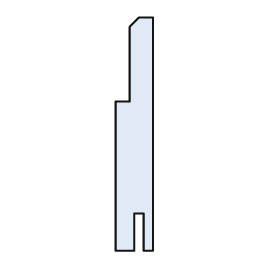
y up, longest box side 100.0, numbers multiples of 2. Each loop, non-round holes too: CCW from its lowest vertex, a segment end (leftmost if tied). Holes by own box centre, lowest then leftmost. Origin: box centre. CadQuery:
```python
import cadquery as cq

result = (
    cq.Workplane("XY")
    .moveTo(-8.0, -50.0)
    .lineTo(0.0, -50.0)
    .lineTo(0.0, -34.0)
    .lineTo(4.0, -34.0)
    .lineTo(4.0, -50.0)
    .lineTo(8.0, -50.0)
    .lineTo(8.0, 50.0)
    .lineTo(2.0, 50.0)
    .lineTo(-2.0, 46.0)
    .lineTo(-2.0, 14.0)
    .lineTo(-8.0, 14.0)
    .close()
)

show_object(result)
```